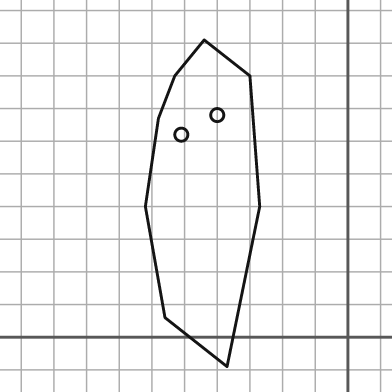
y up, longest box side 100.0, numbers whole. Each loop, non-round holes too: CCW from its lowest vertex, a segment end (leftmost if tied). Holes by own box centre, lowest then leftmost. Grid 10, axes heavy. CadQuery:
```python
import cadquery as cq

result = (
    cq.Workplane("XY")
    .moveTo(-37.0, -9.0)
    .lineTo(-27.0, 40.0)
    .lineTo(-30.0, 80.0)
    .lineTo(-44.0, 91.0)
    .lineTo(-53.0, 80.0)
    .lineTo(-58.0, 67.0)
    .lineTo(-62.0, 40.0)
    .lineTo(-56.0, 6.0)
    .close()
    .moveTo(-51.0, 62.0)
    .circle(2.0)
    .moveTo(-40.0, 68.0)
    .circle(2.0)
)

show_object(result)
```